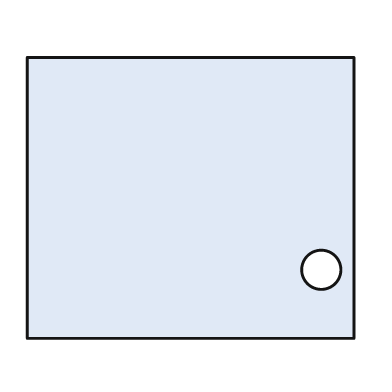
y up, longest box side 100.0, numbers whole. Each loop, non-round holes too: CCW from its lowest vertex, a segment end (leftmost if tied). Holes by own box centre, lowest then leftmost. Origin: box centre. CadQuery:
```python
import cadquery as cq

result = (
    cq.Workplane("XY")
    .moveTo(-50.0, -43.0)
    .lineTo(50.0, -43.0)
    .lineTo(50.0, 43.0)
    .lineTo(-50.0, 43.0)
    .close()
    .moveTo(40.0, -22.0)
    .circle(6.0)
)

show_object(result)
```